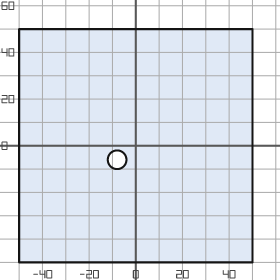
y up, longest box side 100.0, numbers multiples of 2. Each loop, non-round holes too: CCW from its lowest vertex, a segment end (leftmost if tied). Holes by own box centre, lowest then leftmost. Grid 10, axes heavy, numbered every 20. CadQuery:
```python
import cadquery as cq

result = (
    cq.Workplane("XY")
    .moveTo(-50.0, -50.0)
    .lineTo(50.0, -50.0)
    .lineTo(50.0, 50.0)
    .lineTo(-50.0, 50.0)
    .close()
    .moveTo(-8.0, -6.0)
    .circle(4.0)
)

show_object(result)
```